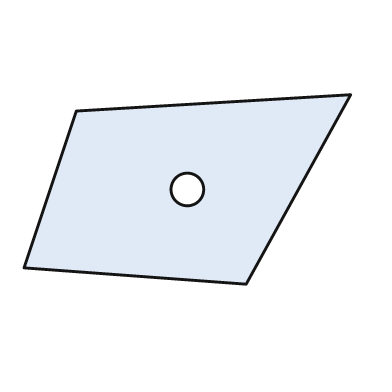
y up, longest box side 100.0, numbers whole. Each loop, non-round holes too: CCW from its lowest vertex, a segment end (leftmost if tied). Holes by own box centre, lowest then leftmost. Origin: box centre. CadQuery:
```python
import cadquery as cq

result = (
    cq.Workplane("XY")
    .moveTo(18.0, -29.0)
    .lineTo(50.0, 29.0)
    .lineTo(-34.0, 24.0)
    .lineTo(-50.0, -24.0)
    .close()
    .moveTo(0.0, 0.0)
    .circle(5.0)
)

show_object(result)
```